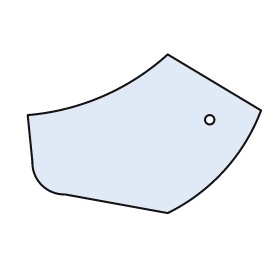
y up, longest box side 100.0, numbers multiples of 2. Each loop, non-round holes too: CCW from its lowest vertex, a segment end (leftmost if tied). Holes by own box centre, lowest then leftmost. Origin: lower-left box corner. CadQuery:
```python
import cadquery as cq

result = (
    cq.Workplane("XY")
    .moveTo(60.0, 0.0)
    .threePointArc((84.0, 18.0), (100.0, 44.0))
    .lineTo(60.0, 68.0)
    .threePointArc((32.0, 50.0), (0.0, 42.0))
    .lineTo(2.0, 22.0)
    .threePointArc((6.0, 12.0), (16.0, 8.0))
    .close()
    .moveTo(78.0, 40.0)
    .circle(2.0)
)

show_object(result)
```